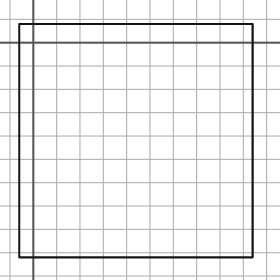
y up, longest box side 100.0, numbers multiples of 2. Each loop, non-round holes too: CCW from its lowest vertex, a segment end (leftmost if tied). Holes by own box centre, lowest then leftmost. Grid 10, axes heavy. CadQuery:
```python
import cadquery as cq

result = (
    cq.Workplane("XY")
    .moveTo(-6.0, -92.0)
    .lineTo(94.0, -92.0)
    .lineTo(94.0, 8.0)
    .lineTo(-6.0, 8.0)
    .close()
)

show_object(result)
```